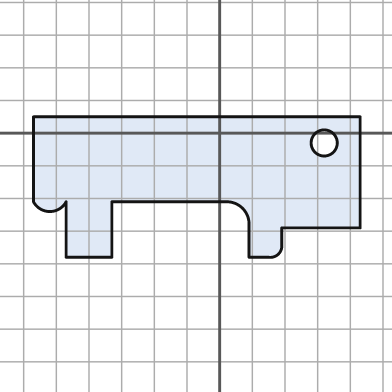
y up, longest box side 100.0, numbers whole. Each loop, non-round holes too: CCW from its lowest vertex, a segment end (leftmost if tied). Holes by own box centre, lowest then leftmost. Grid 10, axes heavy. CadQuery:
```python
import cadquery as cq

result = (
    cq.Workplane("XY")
    .moveTo(-47.0, -38.0)
    .lineTo(-33.0, -38.0)
    .lineTo(-33.0, -21.0)
    .lineTo(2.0, -21.0)
    .threePointArc((7.0, -23.0), (9.0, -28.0))
    .lineTo(9.0, -38.0)
    .lineTo(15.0, -38.0)
    .threePointArc((18.0, -37.0), (19.0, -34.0))
    .lineTo(19.0, -29.0)
    .lineTo(43.0, -29.0)
    .lineTo(43.0, 5.0)
    .lineTo(-57.0, 5.0)
    .lineTo(-57.0, -21.0)
    .threePointArc((-52.0, -24.0), (-47.0, -21.0))
    .close()
    .moveTo(32.0, -3.0)
    .circle(4.0)
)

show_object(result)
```